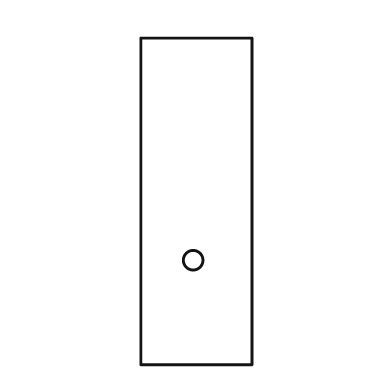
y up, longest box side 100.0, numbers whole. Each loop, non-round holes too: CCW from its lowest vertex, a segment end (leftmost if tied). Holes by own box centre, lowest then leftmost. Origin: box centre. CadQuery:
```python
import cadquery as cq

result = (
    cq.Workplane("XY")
    .moveTo(-17.0, -50.0)
    .lineTo(17.0, -50.0)
    .lineTo(17.0, 50.0)
    .lineTo(-17.0, 50.0)
    .close()
    .moveTo(-1.0, -18.0)
    .circle(3.0)
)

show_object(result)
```